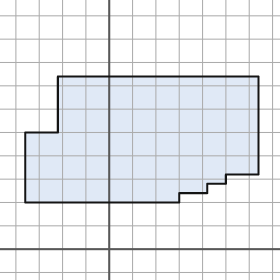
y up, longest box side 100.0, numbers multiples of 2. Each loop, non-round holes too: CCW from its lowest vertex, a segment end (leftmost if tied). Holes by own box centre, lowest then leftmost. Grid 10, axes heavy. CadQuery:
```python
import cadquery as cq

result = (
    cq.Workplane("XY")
    .moveTo(-36.0, 20.0)
    .lineTo(30.0, 20.0)
    .lineTo(30.0, 24.0)
    .lineTo(42.0, 24.0)
    .lineTo(42.0, 28.0)
    .lineTo(50.0, 28.0)
    .lineTo(50.0, 32.0)
    .lineTo(64.0, 32.0)
    .lineTo(64.0, 74.0)
    .lineTo(-22.0, 74.0)
    .lineTo(-22.0, 50.0)
    .lineTo(-36.0, 50.0)
    .close()
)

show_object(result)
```